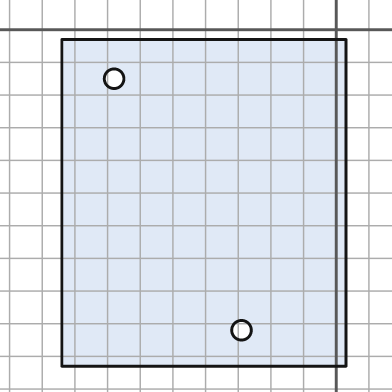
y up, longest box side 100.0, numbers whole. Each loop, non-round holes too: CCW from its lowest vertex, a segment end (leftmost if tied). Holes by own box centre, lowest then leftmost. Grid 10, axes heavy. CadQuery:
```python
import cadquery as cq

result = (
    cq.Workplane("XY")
    .moveTo(-84.0, -103.0)
    .lineTo(3.0, -103.0)
    .lineTo(3.0, -3.0)
    .lineTo(-84.0, -3.0)
    .close()
    .moveTo(-29.0, -92.0)
    .circle(3.0)
    .moveTo(-68.0, -15.0)
    .circle(3.0)
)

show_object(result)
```